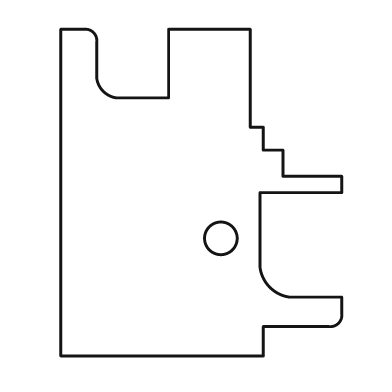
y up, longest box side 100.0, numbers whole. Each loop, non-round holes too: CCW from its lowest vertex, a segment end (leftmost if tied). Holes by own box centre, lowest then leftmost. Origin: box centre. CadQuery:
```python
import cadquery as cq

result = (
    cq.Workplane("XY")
    .moveTo(-43.0, -50.0)
    .lineTo(19.0, -50.0)
    .lineTo(19.0, -41.0)
    .lineTo(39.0, -41.0)
    .threePointArc((42.0, -40.0), (43.0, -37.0))
    .lineTo(43.0, -32.0)
    .lineTo(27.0, -32.0)
    .threePointArc((21.0, -29.0), (18.0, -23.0))
    .lineTo(18.0, 0.0)
    .lineTo(43.0, 0.0)
    .lineTo(43.0, 5.0)
    .lineTo(25.0, 5.0)
    .lineTo(25.0, 13.0)
    .lineTo(19.0, 13.0)
    .lineTo(19.0, 20.0)
    .lineTo(15.0, 20.0)
    .lineTo(15.0, 50.0)
    .lineTo(-10.0, 50.0)
    .lineTo(-10.0, 29.0)
    .lineTo(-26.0, 29.0)
    .threePointArc((-30.0, 31.0), (-32.0, 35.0))
    .lineTo(-32.0, 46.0)
    .threePointArc((-33.0, 49.0), (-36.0, 50.0))
    .lineTo(-43.0, 50.0)
    .close()
    .moveTo(6.0, -14.0)
    .circle(5.0)
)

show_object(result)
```